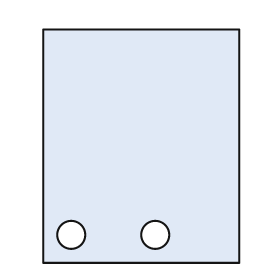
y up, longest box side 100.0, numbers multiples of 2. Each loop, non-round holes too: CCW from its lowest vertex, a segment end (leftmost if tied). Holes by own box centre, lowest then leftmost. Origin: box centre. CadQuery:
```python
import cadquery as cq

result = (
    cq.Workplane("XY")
    .moveTo(-42.0, -50.0)
    .lineTo(42.0, -50.0)
    .lineTo(42.0, 50.0)
    .lineTo(-42.0, 50.0)
    .close()
    .moveTo(-30.0, -38.0)
    .circle(6.0)
    .moveTo(6.0, -38.0)
    .circle(6.0)
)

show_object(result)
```